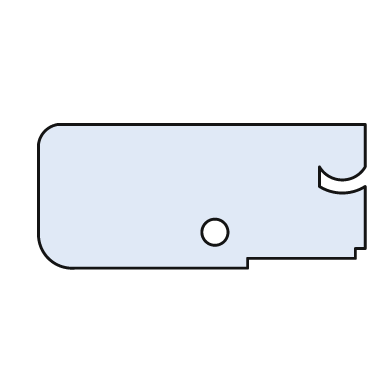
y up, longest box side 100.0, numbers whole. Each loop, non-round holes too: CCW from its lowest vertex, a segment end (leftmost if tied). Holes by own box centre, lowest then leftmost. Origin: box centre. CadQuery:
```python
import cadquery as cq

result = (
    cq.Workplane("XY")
    .moveTo(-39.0, -22.0)
    .lineTo(14.0, -22.0)
    .lineTo(14.0, -19.0)
    .lineTo(47.0, -19.0)
    .lineTo(47.0, -16.0)
    .lineTo(50.0, -16.0)
    .lineTo(50.0, 3.0)
    .threePointArc((43.0, 1.0), (36.0, 3.0))
    .lineTo(36.0, 9.0)
    .threePointArc((43.0, 5.0), (50.0, 9.0))
    .lineTo(50.0, 22.0)
    .lineTo(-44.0, 22.0)
    .threePointArc((-48.0, 20.0), (-50.0, 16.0))
    .lineTo(-50.0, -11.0)
    .threePointArc((-47.0, -19.0), (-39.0, -22.0))
    .close()
    .moveTo(4.0, -11.0)
    .circle(4.0)
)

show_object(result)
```